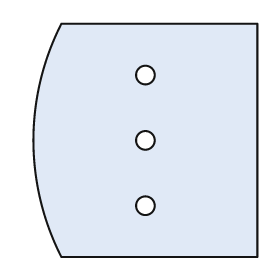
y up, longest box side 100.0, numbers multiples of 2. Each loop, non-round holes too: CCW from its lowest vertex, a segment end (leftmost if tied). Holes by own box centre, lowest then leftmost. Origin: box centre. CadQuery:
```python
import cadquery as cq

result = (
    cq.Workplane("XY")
    .moveTo(-36.0, -50.0)
    .lineTo(48.0, -50.0)
    .lineTo(48.0, 50.0)
    .lineTo(-36.0, 50.0)
    .threePointArc((-48.0, 0.0), (-36.0, -50.0))
    .close()
    .moveTo(0.0, -28.0)
    .circle(4.0)
    .moveTo(0.0, 0.0)
    .circle(4.0)
    .moveTo(0.0, 28.0)
    .circle(4.0)
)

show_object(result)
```